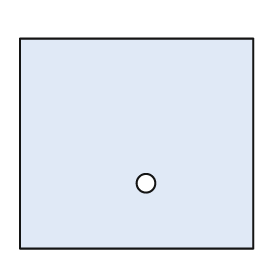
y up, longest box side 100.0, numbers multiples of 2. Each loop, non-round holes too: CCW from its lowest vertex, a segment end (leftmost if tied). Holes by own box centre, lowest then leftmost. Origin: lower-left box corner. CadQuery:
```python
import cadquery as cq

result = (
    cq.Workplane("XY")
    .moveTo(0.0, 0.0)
    .lineTo(100.0, 0.0)
    .lineTo(100.0, 90.0)
    .lineTo(0.0, 90.0)
    .close()
    .moveTo(54.0, 28.0)
    .circle(4.0)
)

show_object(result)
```